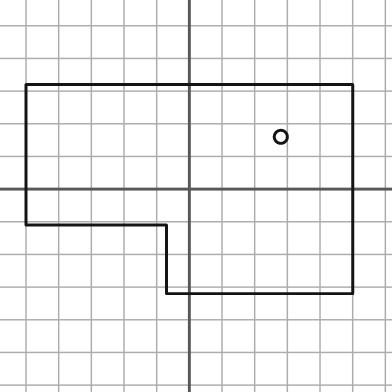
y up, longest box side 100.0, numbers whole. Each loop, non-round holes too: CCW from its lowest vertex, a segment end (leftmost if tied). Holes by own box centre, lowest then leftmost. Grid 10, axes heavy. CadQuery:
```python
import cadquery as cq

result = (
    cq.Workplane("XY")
    .moveTo(-7.0, -32.0)
    .lineTo(50.0, -32.0)
    .lineTo(50.0, 32.0)
    .lineTo(-50.0, 32.0)
    .lineTo(-50.0, -11.0)
    .lineTo(-7.0, -11.0)
    .close()
    .moveTo(28.0, 16.0)
    .circle(2.0)
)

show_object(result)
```